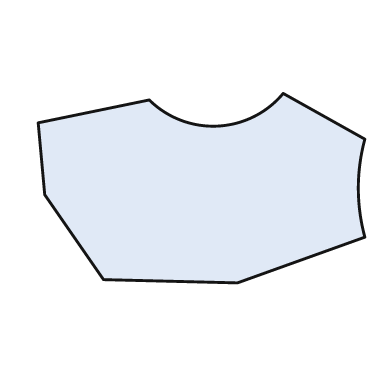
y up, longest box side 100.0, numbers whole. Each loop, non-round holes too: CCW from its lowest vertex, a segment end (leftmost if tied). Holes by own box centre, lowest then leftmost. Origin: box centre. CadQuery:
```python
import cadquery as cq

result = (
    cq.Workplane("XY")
    .moveTo(11.0, -29.0)
    .lineTo(50.0, -15.0)
    .threePointArc((48.0, 0.0), (50.0, 15.0))
    .lineTo(25.0, 29.0)
    .threePointArc((5.0, 19.0), (-16.0, 27.0))
    .lineTo(-50.0, 20.0)
    .lineTo(-48.0, -2.0)
    .lineTo(-30.0, -28.0)
    .close()
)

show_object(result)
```